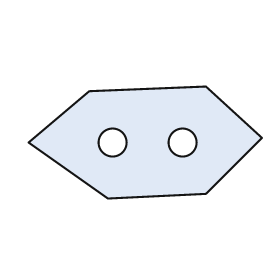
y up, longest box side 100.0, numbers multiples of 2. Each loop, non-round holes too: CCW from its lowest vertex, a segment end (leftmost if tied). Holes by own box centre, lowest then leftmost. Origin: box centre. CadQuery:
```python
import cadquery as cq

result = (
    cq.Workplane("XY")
    .moveTo(-16.0, -24.0)
    .lineTo(26.0, -22.0)
    .lineTo(50.0, 2.0)
    .lineTo(26.0, 24.0)
    .lineTo(-24.0, 22.0)
    .lineTo(-50.0, 0.0)
    .close()
    .moveTo(-14.0, 0.0)
    .circle(6.0)
    .moveTo(16.0, 0.0)
    .circle(6.0)
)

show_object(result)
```